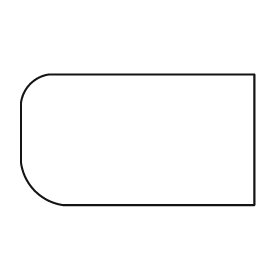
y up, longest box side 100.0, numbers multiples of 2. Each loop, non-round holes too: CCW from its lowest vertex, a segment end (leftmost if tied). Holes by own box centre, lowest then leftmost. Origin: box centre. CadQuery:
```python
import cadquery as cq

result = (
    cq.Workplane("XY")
    .moveTo(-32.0, -28.0)
    .lineTo(50.0, -28.0)
    .lineTo(50.0, 28.0)
    .lineTo(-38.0, 28.0)
    .threePointArc((-46.0, 24.0), (-50.0, 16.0))
    .lineTo(-50.0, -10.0)
    .threePointArc((-44.0, -22.0), (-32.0, -28.0))
    .close()
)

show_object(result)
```